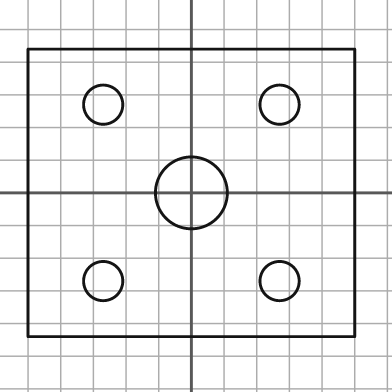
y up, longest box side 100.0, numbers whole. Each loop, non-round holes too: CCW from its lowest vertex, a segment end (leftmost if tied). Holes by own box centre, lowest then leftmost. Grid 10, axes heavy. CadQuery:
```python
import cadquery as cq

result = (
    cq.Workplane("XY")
    .moveTo(-50.0, -44.0)
    .lineTo(50.0, -44.0)
    .lineTo(50.0, 44.0)
    .lineTo(-50.0, 44.0)
    .close()
    .moveTo(-27.0, -27.0)
    .circle(6.0)
    .moveTo(27.0, -27.0)
    .circle(6.0)
    .moveTo(0.0, 0.0)
    .circle(11.0)
    .moveTo(-27.0, 27.0)
    .circle(6.0)
    .moveTo(27.0, 27.0)
    .circle(6.0)
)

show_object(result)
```